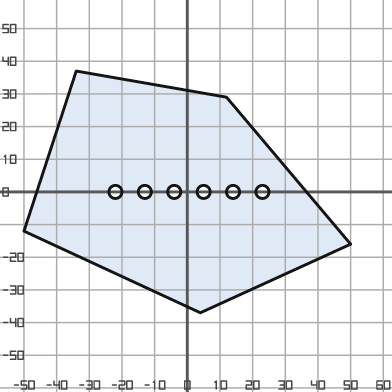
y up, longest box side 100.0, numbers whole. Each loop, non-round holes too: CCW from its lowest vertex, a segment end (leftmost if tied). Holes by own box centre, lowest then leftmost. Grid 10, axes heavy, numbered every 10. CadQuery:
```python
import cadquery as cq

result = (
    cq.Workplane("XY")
    .moveTo(4.0, -37.0)
    .lineTo(50.0, -16.0)
    .lineTo(12.0, 29.0)
    .lineTo(-34.0, 37.0)
    .lineTo(-50.0, -12.0)
    .close()
    .moveTo(-22.0, 0.0)
    .circle(2.0)
    .moveTo(-13.0, 0.0)
    .circle(2.0)
    .moveTo(-4.0, 0.0)
    .circle(2.0)
    .moveTo(5.0, 0.0)
    .circle(2.0)
    .moveTo(14.0, 0.0)
    .circle(2.0)
    .moveTo(23.0, 0.0)
    .circle(2.0)
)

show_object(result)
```